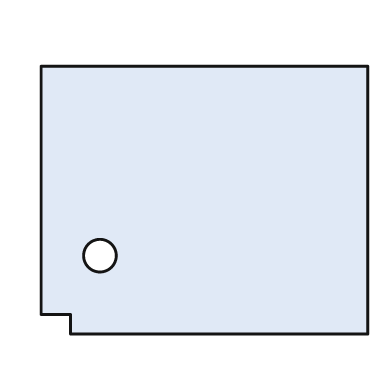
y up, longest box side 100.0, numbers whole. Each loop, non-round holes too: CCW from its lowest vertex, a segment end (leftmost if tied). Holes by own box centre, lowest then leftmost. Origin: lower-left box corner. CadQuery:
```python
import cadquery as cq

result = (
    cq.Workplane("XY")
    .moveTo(9.0, 0.0)
    .lineTo(100.0, 0.0)
    .lineTo(100.0, 82.0)
    .lineTo(0.0, 82.0)
    .lineTo(0.0, 6.0)
    .lineTo(9.0, 6.0)
    .close()
    .moveTo(18.0, 24.0)
    .circle(5.0)
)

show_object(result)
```